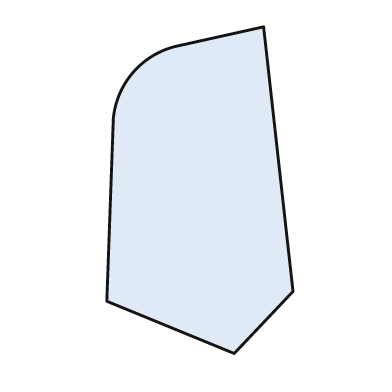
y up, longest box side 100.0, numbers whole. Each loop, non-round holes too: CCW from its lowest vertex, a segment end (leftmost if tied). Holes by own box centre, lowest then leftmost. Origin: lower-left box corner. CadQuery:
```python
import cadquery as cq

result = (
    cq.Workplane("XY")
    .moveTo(39.0, 0.0)
    .lineTo(57.0, 19.0)
    .lineTo(48.0, 100.0)
    .lineTo(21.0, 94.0)
    .threePointArc((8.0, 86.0), (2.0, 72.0))
    .lineTo(0.0, 16.0)
    .close()
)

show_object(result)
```